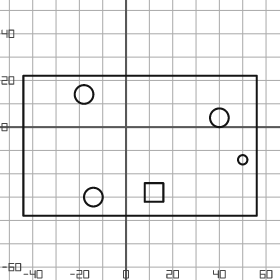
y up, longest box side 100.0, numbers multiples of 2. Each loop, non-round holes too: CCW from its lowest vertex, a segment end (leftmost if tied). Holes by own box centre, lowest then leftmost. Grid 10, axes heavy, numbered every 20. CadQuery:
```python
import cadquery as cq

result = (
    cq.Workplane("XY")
    .moveTo(-44.0, -38.0)
    .lineTo(56.0, -38.0)
    .lineTo(56.0, 22.0)
    .lineTo(-44.0, 22.0)
    .close()
    .moveTo(-14.0, -30.0)
    .circle(4.0)
    .moveTo(8.0, -32.0)
    .lineTo(16.0, -32.0)
    .lineTo(16.0, -24.0)
    .lineTo(8.0, -24.0)
    .close()
    .moveTo(50.0, -14.0)
    .circle(2.0)
    .moveTo(40.0, 4.0)
    .circle(4.0)
    .moveTo(-18.0, 14.0)
    .circle(4.0)
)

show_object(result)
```